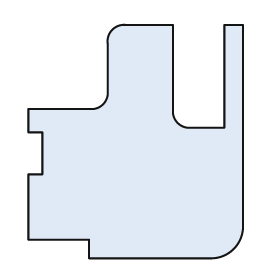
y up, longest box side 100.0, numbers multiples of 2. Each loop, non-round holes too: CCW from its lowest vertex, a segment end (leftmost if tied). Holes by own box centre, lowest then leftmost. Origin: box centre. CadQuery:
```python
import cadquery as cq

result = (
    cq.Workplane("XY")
    .moveTo(-20.0, -50.0)
    .lineTo(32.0, -50.0)
    .threePointArc((42.0, -46.0), (46.0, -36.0))
    .lineTo(46.0, 50.0)
    .lineTo(38.0, 50.0)
    .lineTo(38.0, 6.0)
    .lineTo(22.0, 6.0)
    .threePointArc((18.0, 8.0), (16.0, 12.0))
    .lineTo(16.0, 50.0)
    .lineTo(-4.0, 50.0)
    .threePointArc((-10.0, 48.0), (-12.0, 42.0))
    .lineTo(-12.0, 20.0)
    .threePointArc((-14.0, 16.0), (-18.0, 14.0))
    .lineTo(-46.0, 14.0)
    .lineTo(-46.0, 4.0)
    .lineTo(-40.0, 4.0)
    .lineTo(-40.0, -14.0)
    .lineTo(-46.0, -14.0)
    .lineTo(-46.0, -42.0)
    .lineTo(-20.0, -42.0)
    .close()
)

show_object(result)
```